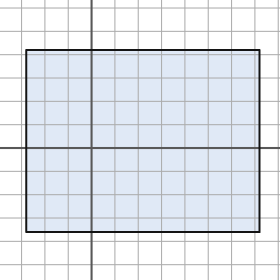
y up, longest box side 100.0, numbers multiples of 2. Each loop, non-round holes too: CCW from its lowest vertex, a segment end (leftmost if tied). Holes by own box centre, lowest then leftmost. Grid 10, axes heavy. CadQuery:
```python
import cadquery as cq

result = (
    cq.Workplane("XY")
    .moveTo(-28.0, -36.0)
    .lineTo(72.0, -36.0)
    .lineTo(72.0, 42.0)
    .lineTo(-28.0, 42.0)
    .close()
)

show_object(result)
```